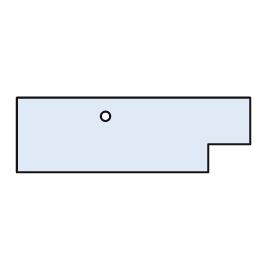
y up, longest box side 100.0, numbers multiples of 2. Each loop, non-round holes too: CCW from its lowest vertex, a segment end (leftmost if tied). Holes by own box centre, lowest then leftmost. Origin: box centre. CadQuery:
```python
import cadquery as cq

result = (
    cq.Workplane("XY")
    .moveTo(-50.0, -16.0)
    .lineTo(32.0, -16.0)
    .lineTo(32.0, -4.0)
    .lineTo(50.0, -4.0)
    .lineTo(50.0, 16.0)
    .lineTo(-50.0, 16.0)
    .close()
    .moveTo(-12.0, 8.0)
    .circle(2.0)
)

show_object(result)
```